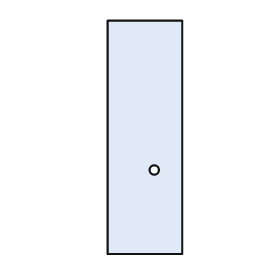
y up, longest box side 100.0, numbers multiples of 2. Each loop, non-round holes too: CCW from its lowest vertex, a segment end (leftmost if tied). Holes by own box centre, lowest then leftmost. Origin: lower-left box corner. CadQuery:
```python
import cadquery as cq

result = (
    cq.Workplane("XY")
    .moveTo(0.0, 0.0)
    .lineTo(32.0, 0.0)
    .lineTo(32.0, 100.0)
    .lineTo(0.0, 100.0)
    .close()
    .moveTo(20.0, 36.0)
    .circle(2.0)
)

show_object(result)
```